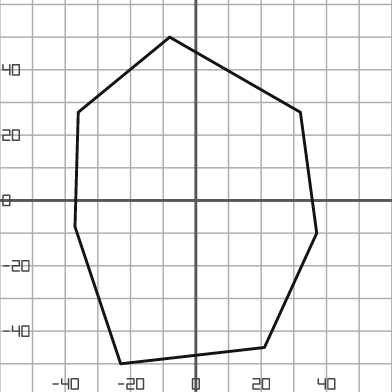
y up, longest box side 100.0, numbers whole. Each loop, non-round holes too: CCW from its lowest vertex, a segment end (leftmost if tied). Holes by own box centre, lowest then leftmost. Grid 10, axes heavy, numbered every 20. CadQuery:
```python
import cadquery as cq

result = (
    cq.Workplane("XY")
    .moveTo(-23.0, -50.0)
    .lineTo(21.0, -45.0)
    .lineTo(37.0, -10.0)
    .lineTo(32.0, 27.0)
    .lineTo(-8.0, 50.0)
    .lineTo(-36.0, 27.0)
    .lineTo(-37.0, -8.0)
    .close()
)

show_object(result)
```